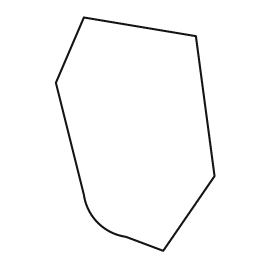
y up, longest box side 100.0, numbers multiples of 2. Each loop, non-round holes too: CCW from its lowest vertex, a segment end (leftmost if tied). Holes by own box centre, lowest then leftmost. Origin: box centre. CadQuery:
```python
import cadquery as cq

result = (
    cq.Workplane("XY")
    .moveTo(12.0, -50.0)
    .lineTo(34.0, -18.0)
    .lineTo(26.0, 42.0)
    .lineTo(-22.0, 50.0)
    .lineTo(-34.0, 22.0)
    .lineTo(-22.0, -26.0)
    .threePointArc((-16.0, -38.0), (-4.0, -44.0))
    .close()
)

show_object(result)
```